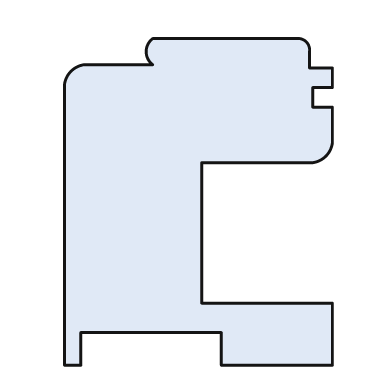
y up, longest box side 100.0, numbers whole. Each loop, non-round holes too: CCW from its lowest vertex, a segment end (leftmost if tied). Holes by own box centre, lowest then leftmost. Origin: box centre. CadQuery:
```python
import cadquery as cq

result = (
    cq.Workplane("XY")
    .moveTo(-41.0, -50.0)
    .lineTo(-36.0, -50.0)
    .lineTo(-36.0, -40.0)
    .lineTo(7.0, -40.0)
    .lineTo(7.0, -50.0)
    .lineTo(41.0, -50.0)
    .lineTo(41.0, -31.0)
    .lineTo(1.0, -31.0)
    .lineTo(1.0, 12.0)
    .lineTo(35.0, 12.0)
    .threePointArc((39.0, 14.0), (41.0, 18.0))
    .lineTo(41.0, 29.0)
    .lineTo(35.0, 29.0)
    .lineTo(35.0, 35.0)
    .lineTo(41.0, 35.0)
    .lineTo(41.0, 41.0)
    .lineTo(34.0, 41.0)
    .lineTo(34.0, 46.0)
    .threePointArc((33.0, 49.0), (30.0, 50.0))
    .lineTo(-14.0, 50.0)
    .threePointArc((-16.0, 46.0), (-14.0, 42.0))
    .lineTo(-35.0, 42.0)
    .threePointArc((-39.0, 40.0), (-41.0, 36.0))
    .close()
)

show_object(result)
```